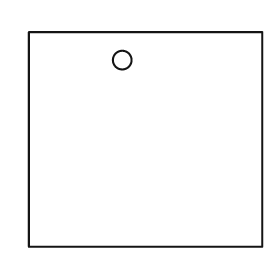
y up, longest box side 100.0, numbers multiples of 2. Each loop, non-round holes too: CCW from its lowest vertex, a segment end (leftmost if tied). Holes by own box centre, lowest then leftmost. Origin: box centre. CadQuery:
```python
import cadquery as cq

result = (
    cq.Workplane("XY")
    .moveTo(-50.0, -46.0)
    .lineTo(50.0, -46.0)
    .lineTo(50.0, 46.0)
    .lineTo(-50.0, 46.0)
    .close()
    .moveTo(-10.0, 34.0)
    .circle(4.0)
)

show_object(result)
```